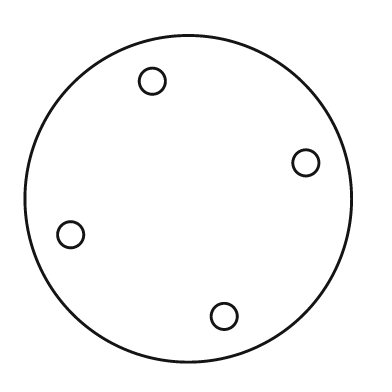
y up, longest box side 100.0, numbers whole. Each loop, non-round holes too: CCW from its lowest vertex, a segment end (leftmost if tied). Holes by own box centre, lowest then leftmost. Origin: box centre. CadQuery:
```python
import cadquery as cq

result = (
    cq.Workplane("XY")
    .moveTo(0.0, 0.0)
    .circle(50.0)
    .moveTo(11.0, -36.0)
    .circle(4.0)
    .moveTo(-36.0, -11.0)
    .circle(4.0)
    .moveTo(36.0, 11.0)
    .circle(4.0)
    .moveTo(-11.0, 36.0)
    .circle(4.0)
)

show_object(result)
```